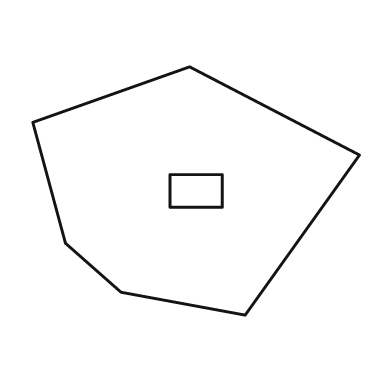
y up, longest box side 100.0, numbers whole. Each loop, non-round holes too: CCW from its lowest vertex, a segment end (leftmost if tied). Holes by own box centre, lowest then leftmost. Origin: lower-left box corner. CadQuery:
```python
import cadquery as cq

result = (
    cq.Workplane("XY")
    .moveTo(65.0, 0.0)
    .lineTo(100.0, 49.0)
    .lineTo(48.0, 76.0)
    .lineTo(0.0, 59.0)
    .lineTo(10.0, 22.0)
    .lineTo(27.0, 7.0)
    .close()
    .moveTo(42.0, 33.0)
    .lineTo(58.0, 33.0)
    .lineTo(58.0, 43.0)
    .lineTo(42.0, 43.0)
    .close()
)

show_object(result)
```